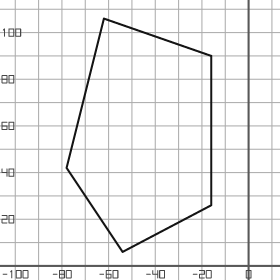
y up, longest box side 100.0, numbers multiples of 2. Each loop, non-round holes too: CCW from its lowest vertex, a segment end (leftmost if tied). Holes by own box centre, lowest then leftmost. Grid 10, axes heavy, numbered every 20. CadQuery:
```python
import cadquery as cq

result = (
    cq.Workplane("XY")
    .moveTo(-54.0, 6.0)
    .lineTo(-16.0, 26.0)
    .lineTo(-16.0, 90.0)
    .lineTo(-62.0, 106.0)
    .lineTo(-78.0, 42.0)
    .close()
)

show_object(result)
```